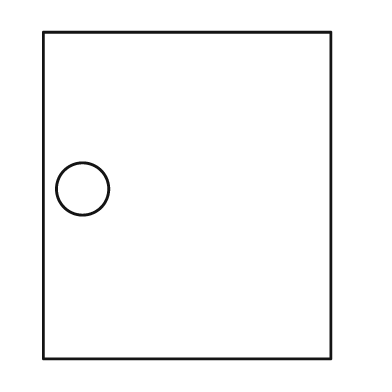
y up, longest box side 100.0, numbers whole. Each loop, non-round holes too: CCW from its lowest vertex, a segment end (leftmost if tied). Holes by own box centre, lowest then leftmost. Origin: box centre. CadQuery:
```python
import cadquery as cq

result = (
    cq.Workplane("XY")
    .moveTo(-44.0, -50.0)
    .lineTo(44.0, -50.0)
    .lineTo(44.0, 50.0)
    .lineTo(-44.0, 50.0)
    .close()
    .moveTo(-32.0, 2.0)
    .circle(8.0)
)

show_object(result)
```